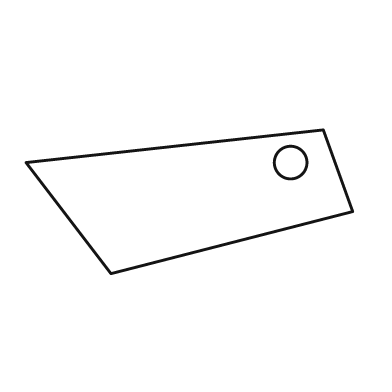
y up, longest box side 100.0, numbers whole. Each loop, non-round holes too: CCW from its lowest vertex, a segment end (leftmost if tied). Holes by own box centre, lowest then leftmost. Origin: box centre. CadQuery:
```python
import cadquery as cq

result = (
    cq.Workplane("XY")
    .moveTo(-24.0, -22.0)
    .lineTo(50.0, -3.0)
    .lineTo(41.0, 22.0)
    .lineTo(-50.0, 12.0)
    .close()
    .moveTo(31.0, 12.0)
    .circle(5.0)
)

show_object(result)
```